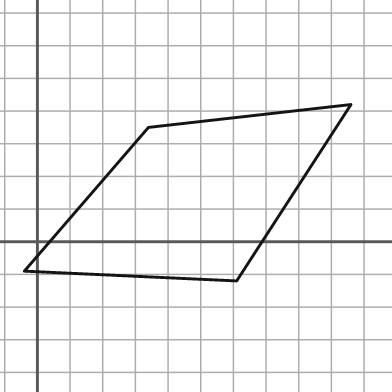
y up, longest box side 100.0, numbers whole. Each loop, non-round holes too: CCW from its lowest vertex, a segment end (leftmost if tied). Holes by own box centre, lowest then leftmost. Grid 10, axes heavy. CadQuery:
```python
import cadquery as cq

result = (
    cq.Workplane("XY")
    .moveTo(61.0, -12.0)
    .lineTo(96.0, 42.0)
    .lineTo(34.0, 35.0)
    .lineTo(-4.0, -9.0)
    .close()
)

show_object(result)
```